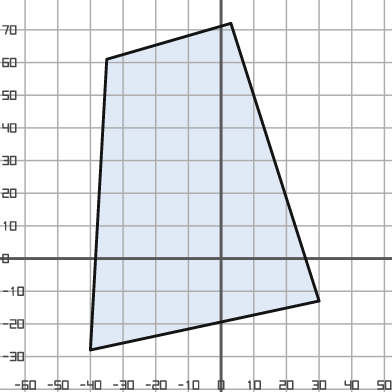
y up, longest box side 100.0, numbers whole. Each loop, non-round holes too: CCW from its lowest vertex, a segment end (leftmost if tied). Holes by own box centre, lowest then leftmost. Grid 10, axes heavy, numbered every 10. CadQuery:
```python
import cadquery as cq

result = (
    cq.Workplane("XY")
    .moveTo(-40.0, -28.0)
    .lineTo(30.0, -13.0)
    .lineTo(3.0, 72.0)
    .lineTo(-35.0, 61.0)
    .close()
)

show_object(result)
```